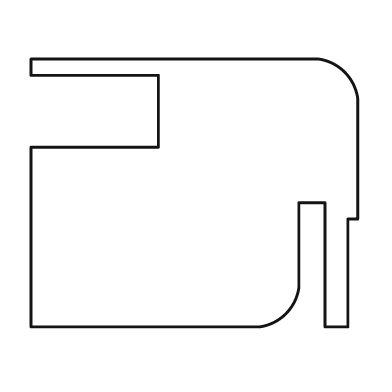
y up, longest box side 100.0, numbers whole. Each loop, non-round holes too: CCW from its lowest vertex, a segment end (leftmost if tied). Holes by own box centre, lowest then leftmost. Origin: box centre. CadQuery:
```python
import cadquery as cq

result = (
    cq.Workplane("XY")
    .moveTo(-50.0, -41.0)
    .lineTo(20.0, -41.0)
    .threePointArc((28.0, -37.0), (32.0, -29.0))
    .lineTo(32.0, -3.0)
    .lineTo(40.0, -3.0)
    .lineTo(40.0, -41.0)
    .lineTo(47.0, -41.0)
    .lineTo(47.0, -8.0)
    .lineTo(50.0, -8.0)
    .lineTo(50.0, 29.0)
    .threePointArc((46.0, 37.0), (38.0, 41.0))
    .lineTo(-50.0, 41.0)
    .lineTo(-50.0, 36.0)
    .lineTo(-11.0, 36.0)
    .lineTo(-11.0, 14.0)
    .lineTo(-50.0, 14.0)
    .close()
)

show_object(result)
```